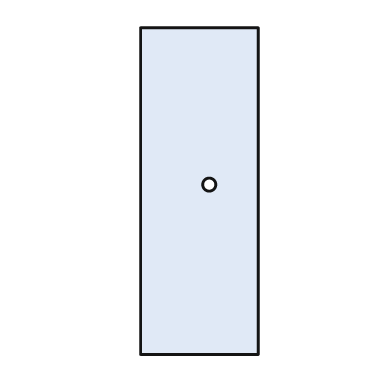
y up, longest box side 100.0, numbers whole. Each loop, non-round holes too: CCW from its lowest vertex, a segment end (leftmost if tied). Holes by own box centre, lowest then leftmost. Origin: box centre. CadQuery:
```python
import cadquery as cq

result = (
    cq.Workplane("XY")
    .moveTo(-18.0, -50.0)
    .lineTo(18.0, -50.0)
    .lineTo(18.0, 50.0)
    .lineTo(-18.0, 50.0)
    .close()
    .moveTo(3.0, 2.0)
    .circle(2.0)
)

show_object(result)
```